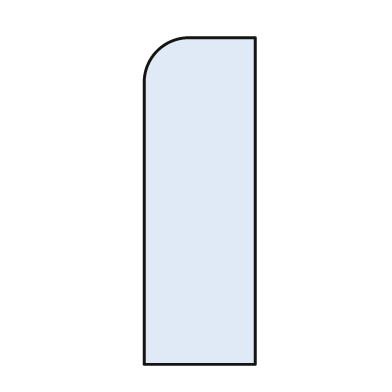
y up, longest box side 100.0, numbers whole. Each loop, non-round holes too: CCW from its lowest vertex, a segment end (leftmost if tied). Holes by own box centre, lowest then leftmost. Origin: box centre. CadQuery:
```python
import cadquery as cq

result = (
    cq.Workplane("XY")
    .moveTo(-17.0, -50.0)
    .lineTo(17.0, -50.0)
    .lineTo(17.0, 50.0)
    .lineTo(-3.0, 50.0)
    .threePointArc((-13.0, 46.0), (-17.0, 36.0))
    .close()
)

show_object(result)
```